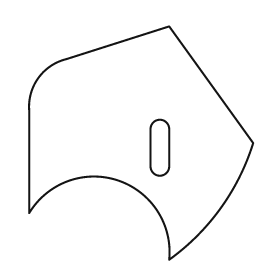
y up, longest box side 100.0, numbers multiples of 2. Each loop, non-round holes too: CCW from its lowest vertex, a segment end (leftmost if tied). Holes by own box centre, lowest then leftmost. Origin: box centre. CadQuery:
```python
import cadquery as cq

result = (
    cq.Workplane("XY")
    .moveTo(12.0, -50.0)
    .threePointArc((34.0, -28.0), (48.0, 0.0))
    .lineTo(12.0, 50.0)
    .lineTo(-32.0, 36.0)
    .threePointArc((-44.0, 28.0), (-48.0, 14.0))
    .lineTo(-48.0, -30.0)
    .threePointArc((-10.0, -16.0), (12.0, -50.0))
    .close()
    .moveTo(4.0, -10.0)
    .threePointArc((8.0, -14.0), (12.0, -10.0))
    .lineTo(12.0, 6.0)
    .threePointArc((8.0, 10.0), (4.0, 6.0))
    .close()
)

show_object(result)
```